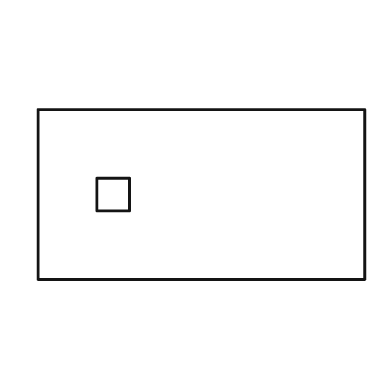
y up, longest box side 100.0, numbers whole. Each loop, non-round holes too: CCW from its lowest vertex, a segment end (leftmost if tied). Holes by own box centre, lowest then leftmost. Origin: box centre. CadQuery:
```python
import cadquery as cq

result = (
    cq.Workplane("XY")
    .moveTo(-50.0, -26.0)
    .lineTo(50.0, -26.0)
    .lineTo(50.0, 26.0)
    .lineTo(-50.0, 26.0)
    .close()
    .moveTo(-32.0, -5.0)
    .lineTo(-22.0, -5.0)
    .lineTo(-22.0, 5.0)
    .lineTo(-32.0, 5.0)
    .close()
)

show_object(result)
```